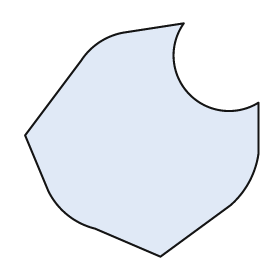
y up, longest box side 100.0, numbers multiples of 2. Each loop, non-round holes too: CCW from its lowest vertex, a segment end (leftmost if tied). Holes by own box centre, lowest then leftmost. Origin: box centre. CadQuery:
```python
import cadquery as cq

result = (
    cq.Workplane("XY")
    .moveTo(8.0, -50.0)
    .lineTo(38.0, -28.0)
    .threePointArc((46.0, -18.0), (50.0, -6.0))
    .lineTo(50.0, 16.0)
    .threePointArc((20.0, 20.0), (18.0, 50.0))
    .lineTo(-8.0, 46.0)
    .threePointArc((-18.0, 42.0), (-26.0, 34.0))
    .lineTo(-50.0, 2.0)
    .lineTo(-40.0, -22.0)
    .threePointArc((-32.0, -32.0), (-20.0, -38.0))
    .close()
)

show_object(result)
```